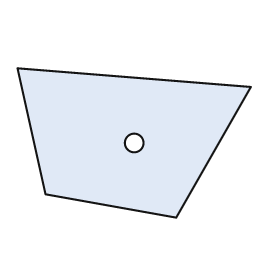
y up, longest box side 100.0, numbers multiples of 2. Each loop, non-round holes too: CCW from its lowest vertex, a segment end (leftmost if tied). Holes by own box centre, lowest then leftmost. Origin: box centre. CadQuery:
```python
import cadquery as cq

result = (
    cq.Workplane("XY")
    .moveTo(18.0, -32.0)
    .lineTo(50.0, 24.0)
    .lineTo(-50.0, 32.0)
    .lineTo(-38.0, -22.0)
    .close()
    .moveTo(0.0, 0.0)
    .circle(4.0)
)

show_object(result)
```